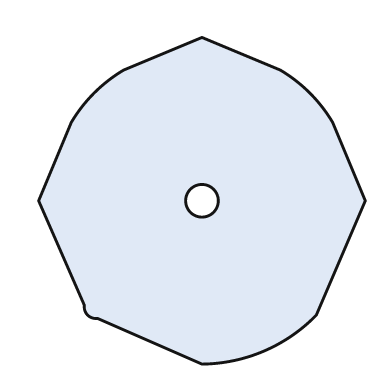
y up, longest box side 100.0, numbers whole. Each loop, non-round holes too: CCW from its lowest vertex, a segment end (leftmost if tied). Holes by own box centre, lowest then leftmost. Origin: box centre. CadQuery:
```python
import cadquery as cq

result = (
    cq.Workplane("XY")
    .moveTo(0.0, -50.0)
    .threePointArc((19.0, -46.0), (35.0, -35.0))
    .lineTo(50.0, 0.0)
    .lineTo(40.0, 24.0)
    .threePointArc((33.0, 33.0), (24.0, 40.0))
    .lineTo(0.0, 50.0)
    .lineTo(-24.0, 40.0)
    .threePointArc((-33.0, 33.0), (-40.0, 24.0))
    .lineTo(-50.0, 0.0)
    .lineTo(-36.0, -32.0)
    .threePointArc((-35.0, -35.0), (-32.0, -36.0))
    .close()
    .moveTo(0.0, 0.0)
    .circle(5.0)
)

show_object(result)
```